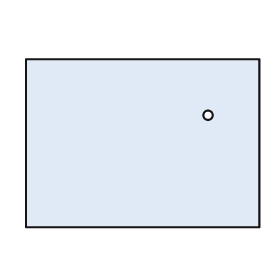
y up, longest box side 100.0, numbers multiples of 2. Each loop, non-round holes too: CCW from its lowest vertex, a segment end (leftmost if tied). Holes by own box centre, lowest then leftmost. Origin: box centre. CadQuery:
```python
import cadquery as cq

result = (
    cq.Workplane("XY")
    .moveTo(-50.0, -36.0)
    .lineTo(50.0, -36.0)
    .lineTo(50.0, 36.0)
    .lineTo(-50.0, 36.0)
    .close()
    .moveTo(28.0, 12.0)
    .circle(2.0)
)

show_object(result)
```